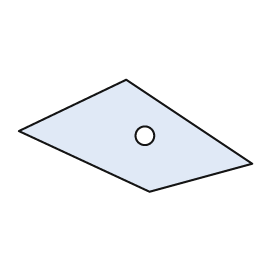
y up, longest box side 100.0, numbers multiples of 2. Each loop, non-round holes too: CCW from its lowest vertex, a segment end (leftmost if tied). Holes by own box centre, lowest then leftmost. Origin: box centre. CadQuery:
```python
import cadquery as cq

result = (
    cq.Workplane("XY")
    .moveTo(6.0, -24.0)
    .lineTo(50.0, -12.0)
    .lineTo(-4.0, 24.0)
    .lineTo(-50.0, 2.0)
    .close()
    .moveTo(4.0, 0.0)
    .circle(4.0)
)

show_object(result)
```